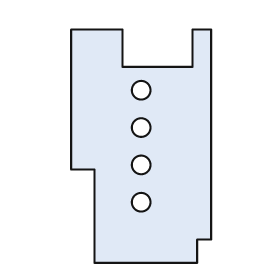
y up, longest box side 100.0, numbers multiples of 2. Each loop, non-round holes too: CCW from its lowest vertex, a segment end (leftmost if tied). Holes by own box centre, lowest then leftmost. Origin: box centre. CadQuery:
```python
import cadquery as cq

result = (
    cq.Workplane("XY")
    .moveTo(-20.0, -50.0)
    .lineTo(24.0, -50.0)
    .lineTo(24.0, -40.0)
    .lineTo(30.0, -40.0)
    .lineTo(30.0, 50.0)
    .lineTo(22.0, 50.0)
    .lineTo(22.0, 34.0)
    .lineTo(-8.0, 34.0)
    .lineTo(-8.0, 50.0)
    .lineTo(-30.0, 50.0)
    .lineTo(-30.0, -10.0)
    .lineTo(-20.0, -10.0)
    .close()
    .moveTo(0.0, -24.0)
    .circle(4.0)
    .moveTo(0.0, -8.0)
    .circle(4.0)
    .moveTo(0.0, 8.0)
    .circle(4.0)
    .moveTo(0.0, 24.0)
    .circle(4.0)
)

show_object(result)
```